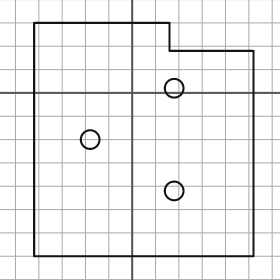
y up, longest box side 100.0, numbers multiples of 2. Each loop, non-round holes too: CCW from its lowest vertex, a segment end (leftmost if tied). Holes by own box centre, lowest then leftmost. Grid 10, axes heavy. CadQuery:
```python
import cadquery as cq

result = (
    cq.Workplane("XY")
    .moveTo(-42.0, -70.0)
    .lineTo(52.0, -70.0)
    .lineTo(52.0, 18.0)
    .lineTo(16.0, 18.0)
    .lineTo(16.0, 30.0)
    .lineTo(-42.0, 30.0)
    .close()
    .moveTo(18.0, -42.0)
    .circle(4.0)
    .moveTo(-18.0, -20.0)
    .circle(4.0)
    .moveTo(18.0, 2.0)
    .circle(4.0)
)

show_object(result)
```